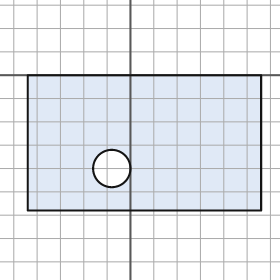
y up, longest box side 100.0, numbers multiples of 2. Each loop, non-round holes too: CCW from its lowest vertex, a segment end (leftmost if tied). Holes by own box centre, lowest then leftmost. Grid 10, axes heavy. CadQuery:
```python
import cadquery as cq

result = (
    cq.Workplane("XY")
    .moveTo(-44.0, -58.0)
    .lineTo(56.0, -58.0)
    .lineTo(56.0, 0.0)
    .lineTo(-44.0, 0.0)
    .close()
    .moveTo(-8.0, -40.0)
    .circle(8.0)
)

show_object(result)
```